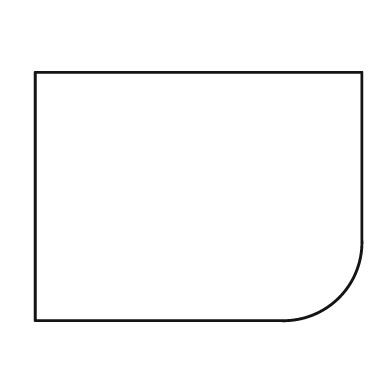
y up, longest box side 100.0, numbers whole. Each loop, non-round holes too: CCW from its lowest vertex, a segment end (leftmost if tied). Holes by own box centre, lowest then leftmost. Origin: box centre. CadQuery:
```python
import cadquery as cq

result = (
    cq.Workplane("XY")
    .moveTo(-50.0, -38.0)
    .lineTo(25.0, -38.0)
    .threePointArc((43.0, -31.0), (50.0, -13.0))
    .lineTo(50.0, 38.0)
    .lineTo(-50.0, 38.0)
    .close()
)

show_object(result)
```